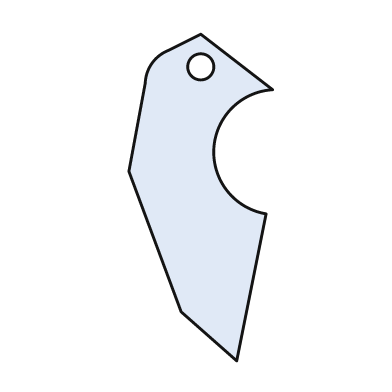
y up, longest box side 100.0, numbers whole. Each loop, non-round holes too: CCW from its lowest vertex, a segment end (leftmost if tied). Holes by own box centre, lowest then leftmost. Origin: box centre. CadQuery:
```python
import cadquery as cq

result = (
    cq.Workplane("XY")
    .moveTo(11.0, -50.0)
    .lineTo(20.0, -5.0)
    .threePointArc((4.0, 15.0), (22.0, 33.0))
    .lineTo(0.0, 50.0)
    .lineTo(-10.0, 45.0)
    .threePointArc((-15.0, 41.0), (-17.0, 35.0))
    .lineTo(-22.0, 8.0)
    .lineTo(-6.0, -35.0)
    .close()
    .moveTo(0.0, 40.0)
    .circle(4.0)
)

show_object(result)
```